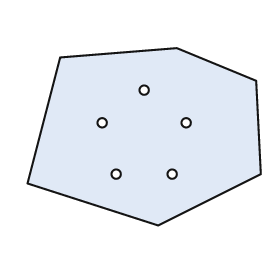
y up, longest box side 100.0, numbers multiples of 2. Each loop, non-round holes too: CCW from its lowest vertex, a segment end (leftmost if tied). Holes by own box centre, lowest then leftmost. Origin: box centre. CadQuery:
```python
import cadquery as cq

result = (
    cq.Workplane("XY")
    .moveTo(6.0, -38.0)
    .lineTo(50.0, -16.0)
    .lineTo(48.0, 24.0)
    .lineTo(14.0, 38.0)
    .lineTo(-36.0, 34.0)
    .lineTo(-50.0, -20.0)
    .close()
    .moveTo(-12.0, -16.0)
    .circle(2.0)
    .moveTo(12.0, -16.0)
    .circle(2.0)
    .moveTo(-18.0, 6.0)
    .circle(2.0)
    .moveTo(18.0, 6.0)
    .circle(2.0)
    .moveTo(0.0, 20.0)
    .circle(2.0)
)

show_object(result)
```